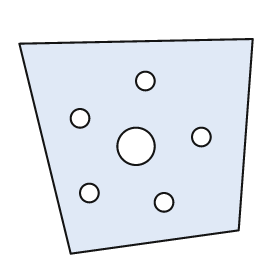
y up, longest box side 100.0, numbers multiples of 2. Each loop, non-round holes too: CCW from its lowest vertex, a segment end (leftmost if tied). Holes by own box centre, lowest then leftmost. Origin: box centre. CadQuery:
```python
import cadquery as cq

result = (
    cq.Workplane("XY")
    .moveTo(-28.0, -46.0)
    .lineTo(44.0, -36.0)
    .lineTo(50.0, 46.0)
    .lineTo(-50.0, 44.0)
    .close()
    .moveTo(12.0, -24.0)
    .circle(4.0)
    .moveTo(-20.0, -20.0)
    .circle(4.0)
    .moveTo(0.0, 0.0)
    .circle(8.0)
    .moveTo(28.0, 4.0)
    .circle(4.0)
    .moveTo(-24.0, 12.0)
    .circle(4.0)
    .moveTo(4.0, 28.0)
    .circle(4.0)
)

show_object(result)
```